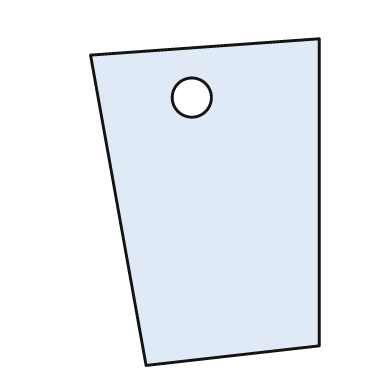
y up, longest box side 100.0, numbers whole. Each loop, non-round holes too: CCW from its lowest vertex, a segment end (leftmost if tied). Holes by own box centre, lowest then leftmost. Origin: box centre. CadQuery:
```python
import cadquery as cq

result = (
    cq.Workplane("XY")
    .moveTo(-18.0, -50.0)
    .lineTo(35.0, -44.0)
    .lineTo(35.0, 50.0)
    .lineTo(-35.0, 45.0)
    .close()
    .moveTo(-4.0, 32.0)
    .circle(6.0)
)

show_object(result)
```